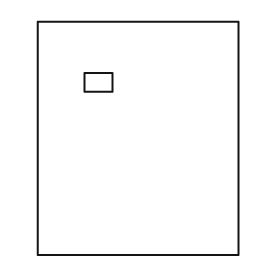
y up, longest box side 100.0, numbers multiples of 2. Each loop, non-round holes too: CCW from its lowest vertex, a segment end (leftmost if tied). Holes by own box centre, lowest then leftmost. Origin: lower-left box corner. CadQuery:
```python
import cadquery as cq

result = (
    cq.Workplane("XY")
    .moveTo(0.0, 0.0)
    .lineTo(86.0, 0.0)
    .lineTo(86.0, 100.0)
    .lineTo(0.0, 100.0)
    .close()
    .moveTo(20.0, 70.0)
    .lineTo(32.0, 70.0)
    .lineTo(32.0, 78.0)
    .lineTo(20.0, 78.0)
    .close()
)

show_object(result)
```